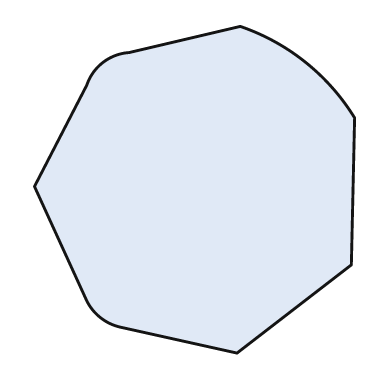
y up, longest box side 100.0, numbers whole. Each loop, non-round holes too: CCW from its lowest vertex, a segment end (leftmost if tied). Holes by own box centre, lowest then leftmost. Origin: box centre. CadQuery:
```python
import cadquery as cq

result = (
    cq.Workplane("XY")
    .moveTo(13.0, -50.0)
    .lineTo(48.0, -23.0)
    .lineTo(49.0, 22.0)
    .threePointArc((34.0, 39.0), (14.0, 50.0))
    .lineTo(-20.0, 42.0)
    .threePointArc((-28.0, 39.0), (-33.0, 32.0))
    .lineTo(-49.0, 1.0)
    .lineTo(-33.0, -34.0)
    .threePointArc((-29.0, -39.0), (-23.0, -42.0))
    .close()
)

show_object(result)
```